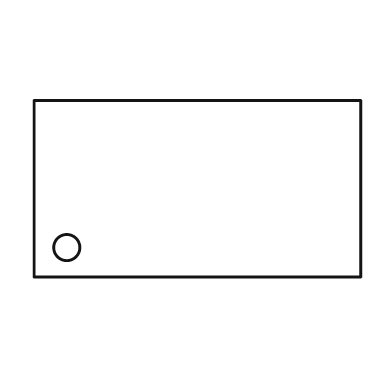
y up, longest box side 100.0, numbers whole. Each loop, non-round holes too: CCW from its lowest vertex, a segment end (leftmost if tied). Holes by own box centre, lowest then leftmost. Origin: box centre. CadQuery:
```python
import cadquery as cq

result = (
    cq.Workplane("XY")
    .moveTo(-50.0, -27.0)
    .lineTo(50.0, -27.0)
    .lineTo(50.0, 27.0)
    .lineTo(-50.0, 27.0)
    .close()
    .moveTo(-40.0, -18.0)
    .circle(4.0)
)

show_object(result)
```